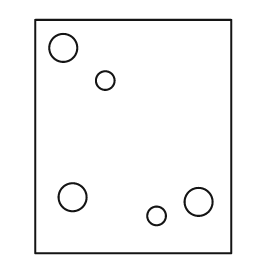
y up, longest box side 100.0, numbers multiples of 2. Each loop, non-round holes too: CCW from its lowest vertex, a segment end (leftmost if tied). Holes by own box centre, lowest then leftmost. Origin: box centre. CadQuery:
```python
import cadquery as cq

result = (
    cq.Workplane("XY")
    .moveTo(-42.0, -50.0)
    .lineTo(42.0, -50.0)
    .lineTo(42.0, 50.0)
    .lineTo(-42.0, 50.0)
    .close()
    .moveTo(10.0, -34.0)
    .circle(4.0)
    .moveTo(28.0, -28.0)
    .circle(6.0)
    .moveTo(-26.0, -26.0)
    .circle(6.0)
    .moveTo(-12.0, 24.0)
    .circle(4.0)
    .moveTo(-30.0, 38.0)
    .circle(6.0)
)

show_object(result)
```